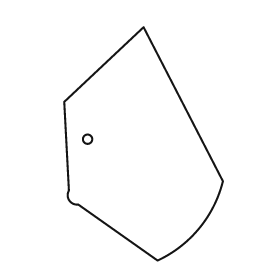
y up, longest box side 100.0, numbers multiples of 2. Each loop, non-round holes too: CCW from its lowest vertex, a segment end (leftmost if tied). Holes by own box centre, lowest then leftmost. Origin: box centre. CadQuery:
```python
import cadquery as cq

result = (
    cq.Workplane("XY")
    .moveTo(6.0, -50.0)
    .threePointArc((24.0, -36.0), (34.0, -16.0))
    .lineTo(0.0, 50.0)
    .lineTo(-34.0, 18.0)
    .lineTo(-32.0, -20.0)
    .threePointArc((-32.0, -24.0), (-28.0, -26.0))
    .close()
    .moveTo(-24.0, 2.0)
    .circle(2.0)
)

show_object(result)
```